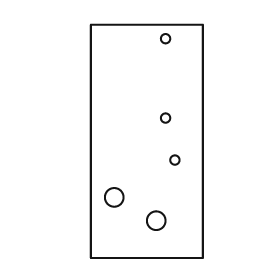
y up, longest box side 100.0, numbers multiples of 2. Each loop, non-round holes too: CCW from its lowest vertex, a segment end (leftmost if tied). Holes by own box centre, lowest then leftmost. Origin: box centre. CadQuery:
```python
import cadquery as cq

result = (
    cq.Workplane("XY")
    .moveTo(-24.0, -50.0)
    .lineTo(24.0, -50.0)
    .lineTo(24.0, 50.0)
    .lineTo(-24.0, 50.0)
    .close()
    .moveTo(4.0, -34.0)
    .circle(4.0)
    .moveTo(-14.0, -24.0)
    .circle(4.0)
    .moveTo(12.0, -8.0)
    .circle(2.0)
    .moveTo(8.0, 10.0)
    .circle(2.0)
    .moveTo(8.0, 44.0)
    .circle(2.0)
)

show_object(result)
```